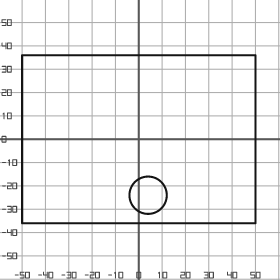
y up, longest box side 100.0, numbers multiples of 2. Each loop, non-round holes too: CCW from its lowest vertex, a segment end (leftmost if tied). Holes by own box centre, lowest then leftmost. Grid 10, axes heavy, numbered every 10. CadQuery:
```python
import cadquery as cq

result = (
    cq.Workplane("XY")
    .moveTo(-50.0, -36.0)
    .lineTo(50.0, -36.0)
    .lineTo(50.0, 36.0)
    .lineTo(-50.0, 36.0)
    .close()
    .moveTo(4.0, -24.0)
    .circle(8.0)
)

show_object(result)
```